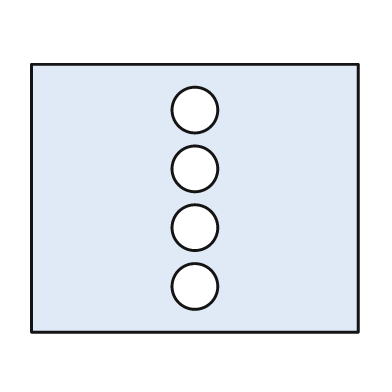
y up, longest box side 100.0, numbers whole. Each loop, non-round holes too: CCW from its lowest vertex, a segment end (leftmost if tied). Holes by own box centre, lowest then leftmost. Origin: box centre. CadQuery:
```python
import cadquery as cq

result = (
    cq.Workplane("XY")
    .moveTo(-50.0, -41.0)
    .lineTo(50.0, -41.0)
    .lineTo(50.0, 41.0)
    .lineTo(-50.0, 41.0)
    .close()
    .moveTo(0.0, -27.0)
    .circle(7.0)
    .moveTo(0.0, -9.0)
    .circle(7.0)
    .moveTo(0.0, 9.0)
    .circle(7.0)
    .moveTo(0.0, 27.0)
    .circle(7.0)
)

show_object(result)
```